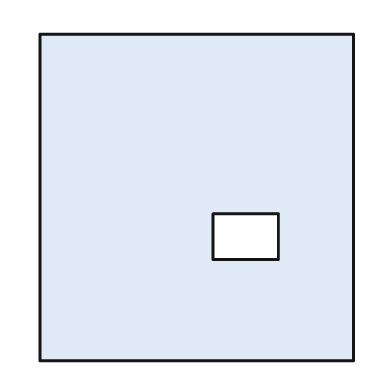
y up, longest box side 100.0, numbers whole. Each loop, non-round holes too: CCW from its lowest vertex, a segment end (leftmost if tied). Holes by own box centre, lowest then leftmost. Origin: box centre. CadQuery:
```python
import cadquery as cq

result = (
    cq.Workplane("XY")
    .moveTo(-48.0, -50.0)
    .lineTo(48.0, -50.0)
    .lineTo(48.0, 50.0)
    .lineTo(-48.0, 50.0)
    .close()
    .moveTo(5.0, -19.0)
    .lineTo(25.0, -19.0)
    .lineTo(25.0, -5.0)
    .lineTo(5.0, -5.0)
    .close()
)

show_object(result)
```